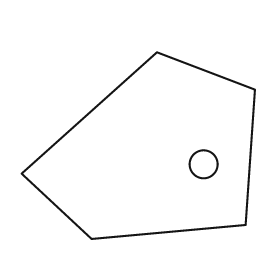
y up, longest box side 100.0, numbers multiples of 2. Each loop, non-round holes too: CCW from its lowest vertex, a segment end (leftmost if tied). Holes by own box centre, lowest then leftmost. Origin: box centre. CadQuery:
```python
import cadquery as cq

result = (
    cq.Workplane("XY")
    .moveTo(-20.0, -40.0)
    .lineTo(46.0, -34.0)
    .lineTo(50.0, 24.0)
    .lineTo(8.0, 40.0)
    .lineTo(-50.0, -12.0)
    .close()
    .moveTo(28.0, -8.0)
    .circle(6.0)
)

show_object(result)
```